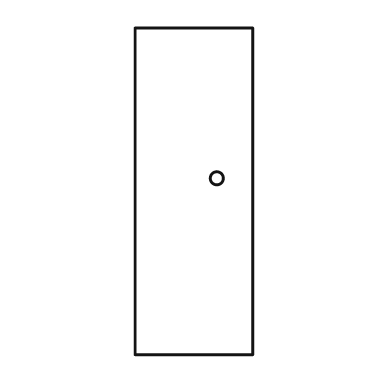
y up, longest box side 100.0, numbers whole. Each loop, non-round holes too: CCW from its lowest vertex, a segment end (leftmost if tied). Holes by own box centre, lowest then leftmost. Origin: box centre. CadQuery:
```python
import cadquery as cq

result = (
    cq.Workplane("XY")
    .moveTo(-18.0, -50.0)
    .lineTo(18.0, -50.0)
    .lineTo(18.0, 50.0)
    .lineTo(-18.0, 50.0)
    .close()
    .moveTo(7.0, 4.0)
    .circle(2.0)
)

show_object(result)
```